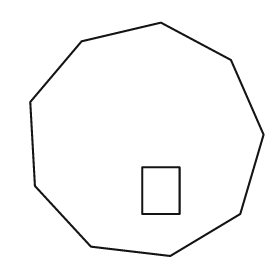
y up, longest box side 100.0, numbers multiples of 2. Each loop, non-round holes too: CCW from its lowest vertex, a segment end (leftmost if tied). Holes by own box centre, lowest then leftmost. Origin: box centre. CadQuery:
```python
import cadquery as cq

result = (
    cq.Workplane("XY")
    .moveTo(10.0, -50.0)
    .lineTo(40.0, -32.0)
    .lineTo(50.0, 2.0)
    .lineTo(36.0, 34.0)
    .lineTo(6.0, 50.0)
    .lineTo(-28.0, 42.0)
    .lineTo(-50.0, 16.0)
    .lineTo(-48.0, -20.0)
    .lineTo(-24.0, -46.0)
    .close()
    .moveTo(-2.0, -32.0)
    .lineTo(14.0, -32.0)
    .lineTo(14.0, -12.0)
    .lineTo(-2.0, -12.0)
    .close()
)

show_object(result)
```